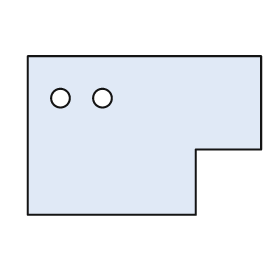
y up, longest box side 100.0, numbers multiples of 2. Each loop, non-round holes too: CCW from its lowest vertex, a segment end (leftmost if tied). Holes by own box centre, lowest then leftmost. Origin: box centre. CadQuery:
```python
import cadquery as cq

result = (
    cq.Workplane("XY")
    .moveTo(-50.0, -34.0)
    .lineTo(22.0, -34.0)
    .lineTo(22.0, -6.0)
    .lineTo(50.0, -6.0)
    .lineTo(50.0, 34.0)
    .lineTo(-50.0, 34.0)
    .close()
    .moveTo(-36.0, 16.0)
    .circle(4.0)
    .moveTo(-18.0, 16.0)
    .circle(4.0)
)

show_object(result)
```